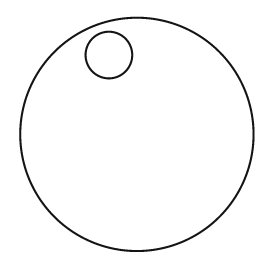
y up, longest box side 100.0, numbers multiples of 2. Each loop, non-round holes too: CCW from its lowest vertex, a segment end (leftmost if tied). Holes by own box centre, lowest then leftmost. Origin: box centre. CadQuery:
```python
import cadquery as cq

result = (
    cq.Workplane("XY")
    .moveTo(0.0, 0.0)
    .circle(50.0)
    .moveTo(-12.0, 34.0)
    .circle(10.0)
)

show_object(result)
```